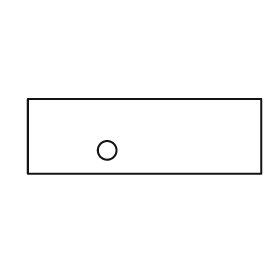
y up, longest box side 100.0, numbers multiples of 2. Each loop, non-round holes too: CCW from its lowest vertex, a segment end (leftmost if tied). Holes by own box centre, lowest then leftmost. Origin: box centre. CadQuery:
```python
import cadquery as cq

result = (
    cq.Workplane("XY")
    .moveTo(-50.0, -16.0)
    .lineTo(50.0, -16.0)
    .lineTo(50.0, 16.0)
    .lineTo(-50.0, 16.0)
    .close()
    .moveTo(-16.0, -6.0)
    .circle(4.0)
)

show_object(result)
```